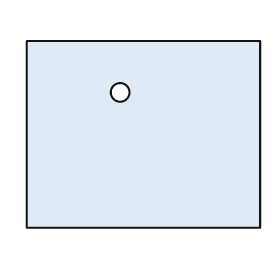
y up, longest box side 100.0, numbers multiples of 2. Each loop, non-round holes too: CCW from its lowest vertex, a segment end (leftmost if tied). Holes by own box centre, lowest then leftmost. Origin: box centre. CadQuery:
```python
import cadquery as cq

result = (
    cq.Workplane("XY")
    .moveTo(-50.0, -40.0)
    .lineTo(50.0, -40.0)
    .lineTo(50.0, 40.0)
    .lineTo(-50.0, 40.0)
    .close()
    .moveTo(-10.0, 18.0)
    .circle(4.0)
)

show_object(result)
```